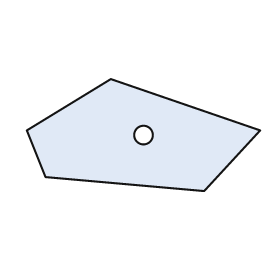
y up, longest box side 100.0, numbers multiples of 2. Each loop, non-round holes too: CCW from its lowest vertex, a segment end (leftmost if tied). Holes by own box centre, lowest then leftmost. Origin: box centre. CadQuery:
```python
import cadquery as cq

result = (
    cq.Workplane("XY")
    .moveTo(26.0, -24.0)
    .lineTo(50.0, 2.0)
    .lineTo(-14.0, 24.0)
    .lineTo(-50.0, 2.0)
    .lineTo(-42.0, -18.0)
    .close()
    .moveTo(0.0, 0.0)
    .circle(4.0)
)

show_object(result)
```